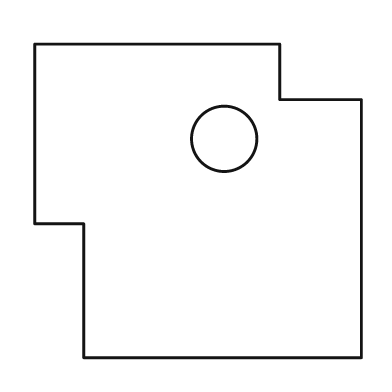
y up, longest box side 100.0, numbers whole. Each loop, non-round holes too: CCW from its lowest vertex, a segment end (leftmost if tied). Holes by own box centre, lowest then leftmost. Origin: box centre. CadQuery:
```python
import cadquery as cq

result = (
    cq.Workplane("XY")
    .moveTo(-35.0, -48.0)
    .lineTo(50.0, -48.0)
    .lineTo(50.0, 31.0)
    .lineTo(25.0, 31.0)
    .lineTo(25.0, 48.0)
    .lineTo(-50.0, 48.0)
    .lineTo(-50.0, -7.0)
    .lineTo(-35.0, -7.0)
    .close()
    .moveTo(8.0, 19.0)
    .circle(10.0)
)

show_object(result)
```